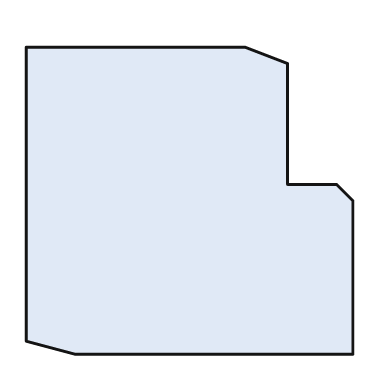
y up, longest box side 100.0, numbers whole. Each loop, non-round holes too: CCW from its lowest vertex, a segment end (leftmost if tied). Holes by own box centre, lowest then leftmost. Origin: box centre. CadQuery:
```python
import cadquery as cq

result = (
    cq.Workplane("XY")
    .moveTo(-35.0, -47.0)
    .lineTo(50.0, -47.0)
    .lineTo(50.0, 0.0)
    .lineTo(45.0, 5.0)
    .lineTo(30.0, 5.0)
    .lineTo(30.0, 42.0)
    .lineTo(17.0, 47.0)
    .lineTo(-50.0, 47.0)
    .lineTo(-50.0, -43.0)
    .close()
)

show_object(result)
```